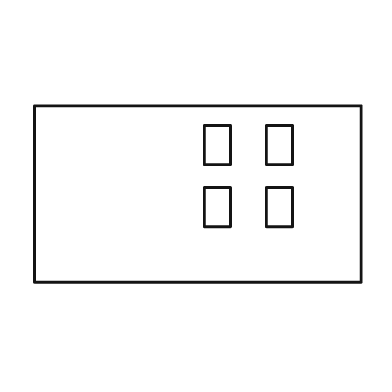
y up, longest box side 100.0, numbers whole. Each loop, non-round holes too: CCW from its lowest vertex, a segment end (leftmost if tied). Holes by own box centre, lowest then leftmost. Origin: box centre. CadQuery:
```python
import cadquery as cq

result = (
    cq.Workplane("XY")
    .moveTo(-50.0, -27.0)
    .lineTo(50.0, -27.0)
    .lineTo(50.0, 27.0)
    .lineTo(-50.0, 27.0)
    .close()
    .moveTo(2.0, -10.0)
    .lineTo(10.0, -10.0)
    .lineTo(10.0, 2.0)
    .lineTo(2.0, 2.0)
    .close()
    .moveTo(21.0, -10.0)
    .lineTo(29.0, -10.0)
    .lineTo(29.0, 2.0)
    .lineTo(21.0, 2.0)
    .close()
    .moveTo(2.0, 9.0)
    .lineTo(10.0, 9.0)
    .lineTo(10.0, 21.0)
    .lineTo(2.0, 21.0)
    .close()
    .moveTo(21.0, 9.0)
    .lineTo(29.0, 9.0)
    .lineTo(29.0, 21.0)
    .lineTo(21.0, 21.0)
    .close()
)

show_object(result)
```